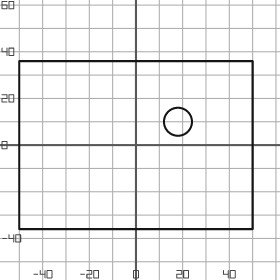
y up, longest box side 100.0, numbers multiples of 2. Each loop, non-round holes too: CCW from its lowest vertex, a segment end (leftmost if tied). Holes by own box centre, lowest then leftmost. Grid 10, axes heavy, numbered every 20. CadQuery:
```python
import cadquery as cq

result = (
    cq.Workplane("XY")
    .moveTo(-50.0, -36.0)
    .lineTo(50.0, -36.0)
    .lineTo(50.0, 36.0)
    .lineTo(-50.0, 36.0)
    .close()
    .moveTo(18.0, 10.0)
    .circle(6.0)
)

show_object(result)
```